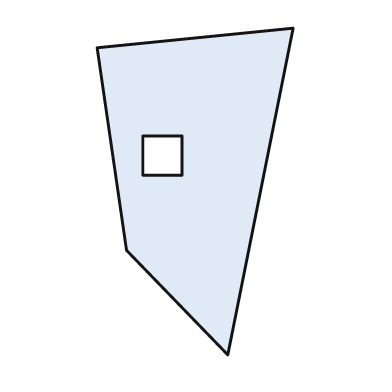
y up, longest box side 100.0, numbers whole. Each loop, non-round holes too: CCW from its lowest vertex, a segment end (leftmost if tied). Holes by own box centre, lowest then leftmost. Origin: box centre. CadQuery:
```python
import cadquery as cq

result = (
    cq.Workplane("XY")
    .moveTo(10.0, -50.0)
    .lineTo(30.0, 50.0)
    .lineTo(-30.0, 44.0)
    .lineTo(-21.0, -18.0)
    .close()
    .moveTo(-16.0, 5.0)
    .lineTo(-4.0, 5.0)
    .lineTo(-4.0, 17.0)
    .lineTo(-16.0, 17.0)
    .close()
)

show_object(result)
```